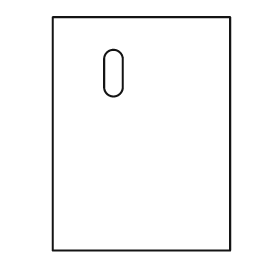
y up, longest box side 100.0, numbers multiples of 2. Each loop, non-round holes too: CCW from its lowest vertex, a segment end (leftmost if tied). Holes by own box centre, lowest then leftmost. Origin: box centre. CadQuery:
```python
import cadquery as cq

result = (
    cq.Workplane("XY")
    .moveTo(-38.0, -50.0)
    .lineTo(38.0, -50.0)
    .lineTo(38.0, 50.0)
    .lineTo(-38.0, 50.0)
    .close()
    .moveTo(-16.0, 20.0)
    .threePointArc((-12.0, 16.0), (-8.0, 20.0))
    .lineTo(-8.0, 32.0)
    .threePointArc((-12.0, 36.0), (-16.0, 32.0))
    .close()
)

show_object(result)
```